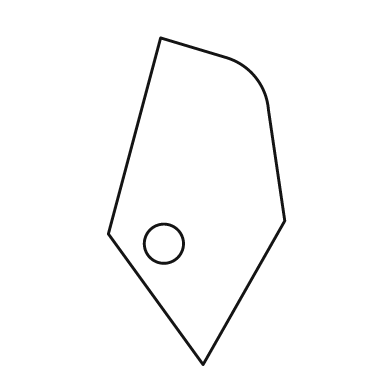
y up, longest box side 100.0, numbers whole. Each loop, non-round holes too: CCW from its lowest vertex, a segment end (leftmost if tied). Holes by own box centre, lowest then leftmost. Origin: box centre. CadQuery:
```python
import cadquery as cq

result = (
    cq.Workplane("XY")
    .moveTo(2.0, -50.0)
    .lineTo(27.0, -6.0)
    .lineTo(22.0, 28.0)
    .threePointArc((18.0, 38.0), (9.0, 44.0))
    .lineTo(-11.0, 50.0)
    .lineTo(-27.0, -10.0)
    .close()
    .moveTo(-10.0, -13.0)
    .circle(6.0)
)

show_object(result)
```